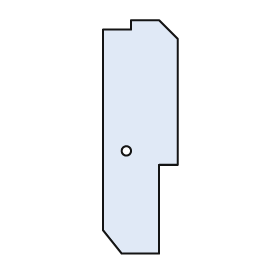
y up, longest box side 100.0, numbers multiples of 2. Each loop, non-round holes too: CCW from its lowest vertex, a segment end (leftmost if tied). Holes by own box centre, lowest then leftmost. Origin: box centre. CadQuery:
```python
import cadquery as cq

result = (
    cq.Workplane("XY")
    .moveTo(-8.0, -50.0)
    .lineTo(8.0, -50.0)
    .lineTo(8.0, -12.0)
    .lineTo(16.0, -12.0)
    .lineTo(16.0, 42.0)
    .lineTo(8.0, 50.0)
    .lineTo(-4.0, 50.0)
    .lineTo(-4.0, 46.0)
    .lineTo(-16.0, 46.0)
    .lineTo(-16.0, -40.0)
    .close()
    .moveTo(-6.0, -6.0)
    .circle(2.0)
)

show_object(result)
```